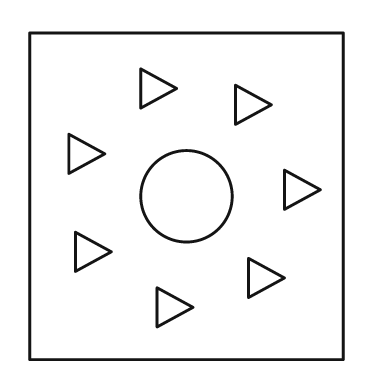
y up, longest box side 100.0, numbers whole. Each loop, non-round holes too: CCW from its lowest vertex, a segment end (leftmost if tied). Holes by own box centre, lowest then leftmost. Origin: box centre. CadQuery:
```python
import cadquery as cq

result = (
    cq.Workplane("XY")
    .moveTo(-48.0, -50.0)
    .lineTo(48.0, -50.0)
    .lineTo(48.0, 50.0)
    .lineTo(-48.0, 50.0)
    .close()
    .moveTo(-9.0, -40.0)
    .lineTo(2.0, -34.0)
    .lineTo(-9.0, -28.0)
    .close()
    .moveTo(19.0, -31.0)
    .lineTo(30.0, -25.0)
    .lineTo(19.0, -19.0)
    .close()
    .moveTo(-34.0, -23.0)
    .lineTo(-23.0, -17.0)
    .lineTo(-34.0, -11.0)
    .close()
    .moveTo(0.0, 0.0)
    .circle(14.0)
    .moveTo(30.0, -4.0)
    .lineTo(41.0, 2.0)
    .lineTo(30.0, 8.0)
    .close()
    .moveTo(-36.0, 7.0)
    .lineTo(-25.0, 13.0)
    .lineTo(-36.0, 19.0)
    .close()
    .moveTo(15.0, 22.0)
    .lineTo(26.0, 28.0)
    .lineTo(15.0, 34.0)
    .close()
    .moveTo(-14.0, 27.0)
    .lineTo(-3.0, 33.0)
    .lineTo(-14.0, 39.0)
    .close()
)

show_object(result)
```